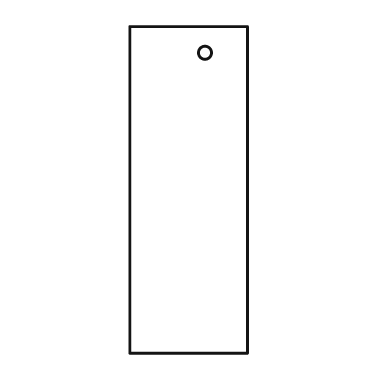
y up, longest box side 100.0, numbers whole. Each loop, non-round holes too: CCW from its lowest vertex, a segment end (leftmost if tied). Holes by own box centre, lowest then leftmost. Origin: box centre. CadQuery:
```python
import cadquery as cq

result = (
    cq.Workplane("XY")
    .moveTo(-18.0, -50.0)
    .lineTo(18.0, -50.0)
    .lineTo(18.0, 50.0)
    .lineTo(-18.0, 50.0)
    .close()
    .moveTo(5.0, 42.0)
    .circle(2.0)
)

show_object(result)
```